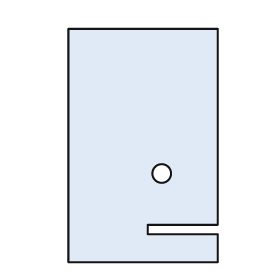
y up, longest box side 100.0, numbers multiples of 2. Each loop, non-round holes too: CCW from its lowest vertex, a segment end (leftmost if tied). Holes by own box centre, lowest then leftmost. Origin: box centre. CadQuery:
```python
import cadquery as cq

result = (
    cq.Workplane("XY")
    .moveTo(-32.0, -50.0)
    .lineTo(32.0, -50.0)
    .lineTo(32.0, -38.0)
    .lineTo(2.0, -38.0)
    .lineTo(2.0, -34.0)
    .lineTo(32.0, -34.0)
    .lineTo(32.0, 50.0)
    .lineTo(-32.0, 50.0)
    .close()
    .moveTo(8.0, -12.0)
    .circle(4.0)
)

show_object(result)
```